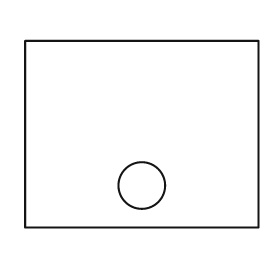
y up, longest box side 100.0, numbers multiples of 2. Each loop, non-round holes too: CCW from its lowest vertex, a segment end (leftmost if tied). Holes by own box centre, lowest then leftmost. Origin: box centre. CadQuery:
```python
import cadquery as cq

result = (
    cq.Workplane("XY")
    .moveTo(-50.0, -40.0)
    .lineTo(50.0, -40.0)
    .lineTo(50.0, 40.0)
    .lineTo(-50.0, 40.0)
    .close()
    .moveTo(0.0, -22.0)
    .circle(10.0)
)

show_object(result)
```